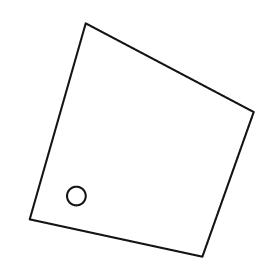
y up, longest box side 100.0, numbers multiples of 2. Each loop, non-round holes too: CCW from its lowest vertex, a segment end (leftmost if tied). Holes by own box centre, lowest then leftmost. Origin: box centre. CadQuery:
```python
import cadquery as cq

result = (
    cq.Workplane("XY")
    .moveTo(26.0, -50.0)
    .lineTo(48.0, 12.0)
    .lineTo(-24.0, 50.0)
    .lineTo(-48.0, -34.0)
    .close()
    .moveTo(-28.0, -24.0)
    .circle(4.0)
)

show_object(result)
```